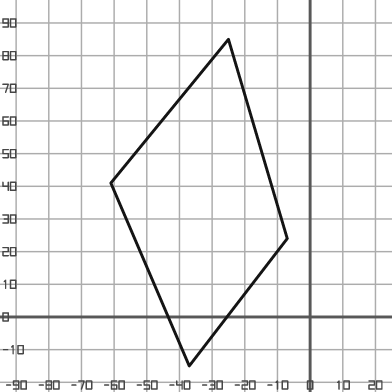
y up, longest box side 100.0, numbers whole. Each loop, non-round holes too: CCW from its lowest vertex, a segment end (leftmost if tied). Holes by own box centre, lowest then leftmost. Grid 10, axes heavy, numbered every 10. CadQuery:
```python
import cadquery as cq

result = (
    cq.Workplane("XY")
    .moveTo(-37.0, -15.0)
    .lineTo(-7.0, 24.0)
    .lineTo(-25.0, 85.0)
    .lineTo(-61.0, 41.0)
    .close()
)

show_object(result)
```